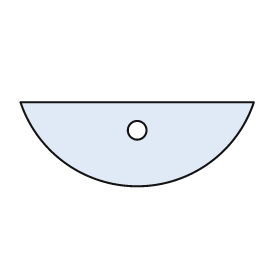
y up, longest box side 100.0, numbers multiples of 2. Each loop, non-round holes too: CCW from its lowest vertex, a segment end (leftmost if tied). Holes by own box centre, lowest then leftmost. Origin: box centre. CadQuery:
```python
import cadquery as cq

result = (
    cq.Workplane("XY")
    .moveTo(-50.0, 18.0)
    .threePointArc((0.0, -18.0), (50.0, 18.0))
    .close()
    .moveTo(0.0, 6.0)
    .circle(4.0)
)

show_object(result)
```